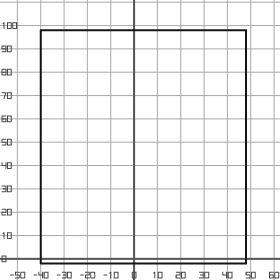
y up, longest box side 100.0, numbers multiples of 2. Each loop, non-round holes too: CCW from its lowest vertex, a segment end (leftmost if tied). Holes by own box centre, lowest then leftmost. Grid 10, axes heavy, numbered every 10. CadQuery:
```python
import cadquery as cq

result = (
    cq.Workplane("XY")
    .moveTo(-40.0, -2.0)
    .lineTo(48.0, -2.0)
    .lineTo(48.0, 98.0)
    .lineTo(-40.0, 98.0)
    .close()
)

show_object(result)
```